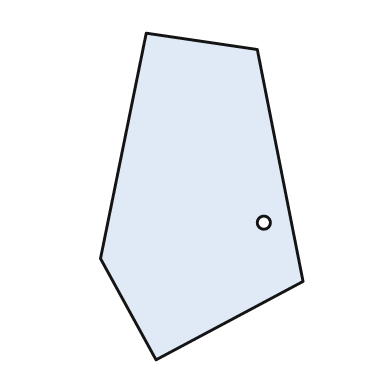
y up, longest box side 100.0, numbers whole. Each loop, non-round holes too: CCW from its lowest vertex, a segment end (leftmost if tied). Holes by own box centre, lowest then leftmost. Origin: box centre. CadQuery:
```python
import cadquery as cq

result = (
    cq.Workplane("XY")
    .moveTo(-14.0, -50.0)
    .lineTo(31.0, -26.0)
    .lineTo(17.0, 45.0)
    .lineTo(-17.0, 50.0)
    .lineTo(-31.0, -19.0)
    .close()
    .moveTo(19.0, -8.0)
    .circle(2.0)
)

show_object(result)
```